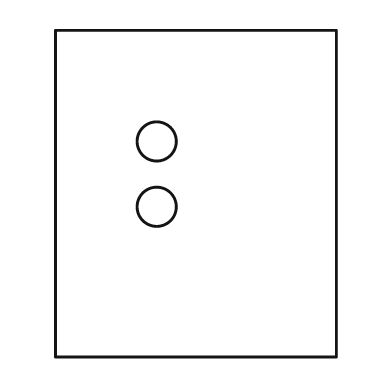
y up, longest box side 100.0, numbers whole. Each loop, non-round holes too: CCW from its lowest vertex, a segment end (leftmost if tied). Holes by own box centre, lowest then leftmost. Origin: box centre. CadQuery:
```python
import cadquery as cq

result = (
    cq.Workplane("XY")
    .moveTo(-43.0, -50.0)
    .lineTo(43.0, -50.0)
    .lineTo(43.0, 50.0)
    .lineTo(-43.0, 50.0)
    .close()
    .moveTo(-12.0, -4.0)
    .circle(6.0)
    .moveTo(-12.0, 16.0)
    .circle(6.0)
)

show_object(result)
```